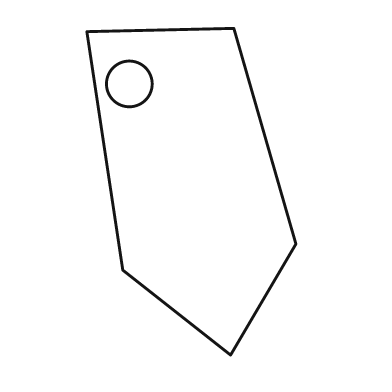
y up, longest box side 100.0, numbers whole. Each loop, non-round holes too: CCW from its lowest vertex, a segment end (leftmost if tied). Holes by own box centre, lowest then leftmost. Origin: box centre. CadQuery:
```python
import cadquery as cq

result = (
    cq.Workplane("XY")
    .moveTo(12.0, -50.0)
    .lineTo(32.0, -16.0)
    .lineTo(13.0, 50.0)
    .lineTo(-32.0, 49.0)
    .lineTo(-21.0, -24.0)
    .close()
    .moveTo(-19.0, 33.0)
    .circle(7.0)
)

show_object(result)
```